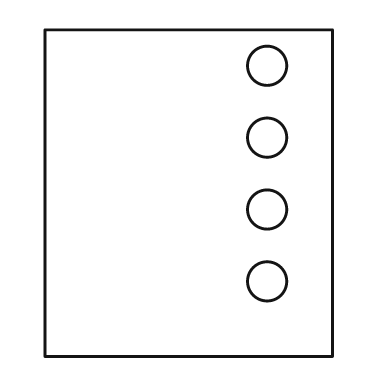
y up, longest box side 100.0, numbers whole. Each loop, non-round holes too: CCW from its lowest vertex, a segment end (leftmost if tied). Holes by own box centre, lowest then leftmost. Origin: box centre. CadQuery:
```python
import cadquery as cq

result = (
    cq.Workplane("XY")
    .moveTo(-44.0, -50.0)
    .lineTo(44.0, -50.0)
    .lineTo(44.0, 50.0)
    .lineTo(-44.0, 50.0)
    .close()
    .moveTo(24.0, -27.0)
    .circle(6.0)
    .moveTo(24.0, -5.0)
    .circle(6.0)
    .moveTo(24.0, 17.0)
    .circle(6.0)
    .moveTo(24.0, 39.0)
    .circle(6.0)
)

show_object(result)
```